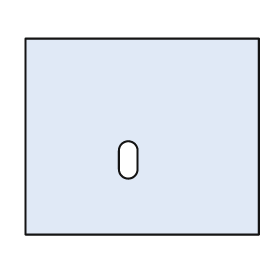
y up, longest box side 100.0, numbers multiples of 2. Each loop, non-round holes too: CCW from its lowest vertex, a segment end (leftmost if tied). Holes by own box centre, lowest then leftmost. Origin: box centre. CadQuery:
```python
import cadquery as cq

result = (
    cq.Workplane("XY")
    .moveTo(-50.0, -42.0)
    .lineTo(50.0, -42.0)
    .lineTo(50.0, 42.0)
    .lineTo(-50.0, 42.0)
    .close()
    .moveTo(-10.0, -14.0)
    .threePointArc((-6.0, -18.0), (-2.0, -14.0))
    .lineTo(-2.0, -6.0)
    .threePointArc((-6.0, -2.0), (-10.0, -6.0))
    .close()
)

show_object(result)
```